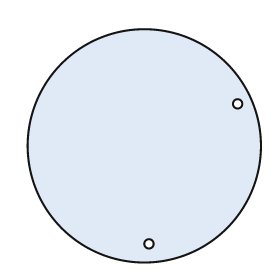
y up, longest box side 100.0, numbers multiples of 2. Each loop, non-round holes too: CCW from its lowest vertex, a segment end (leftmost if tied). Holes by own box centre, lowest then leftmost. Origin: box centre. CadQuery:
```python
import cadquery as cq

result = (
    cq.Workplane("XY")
    .moveTo(0.0, 0.0)
    .circle(50.0)
    .moveTo(2.0, -42.0)
    .circle(2.0)
    .moveTo(40.0, 18.0)
    .circle(2.0)
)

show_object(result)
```